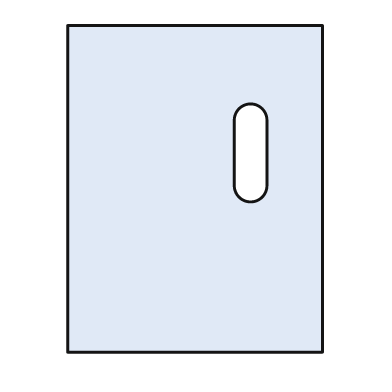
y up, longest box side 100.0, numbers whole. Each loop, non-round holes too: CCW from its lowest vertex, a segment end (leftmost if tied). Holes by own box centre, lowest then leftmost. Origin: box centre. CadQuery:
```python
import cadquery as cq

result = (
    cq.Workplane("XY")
    .moveTo(-39.0, -50.0)
    .lineTo(39.0, -50.0)
    .lineTo(39.0, 50.0)
    .lineTo(-39.0, 50.0)
    .close()
    .moveTo(12.0, 1.0)
    .threePointArc((17.0, -4.0), (22.0, 1.0))
    .lineTo(22.0, 21.0)
    .threePointArc((17.0, 26.0), (12.0, 21.0))
    .close()
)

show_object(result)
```